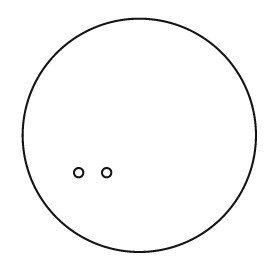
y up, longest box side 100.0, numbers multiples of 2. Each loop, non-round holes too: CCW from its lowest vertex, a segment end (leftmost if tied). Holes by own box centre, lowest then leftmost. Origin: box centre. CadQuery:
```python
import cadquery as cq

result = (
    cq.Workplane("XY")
    .moveTo(0.0, 0.0)
    .circle(50.0)
    .moveTo(-26.0, -16.0)
    .circle(2.0)
    .moveTo(-14.0, -16.0)
    .circle(2.0)
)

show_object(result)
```